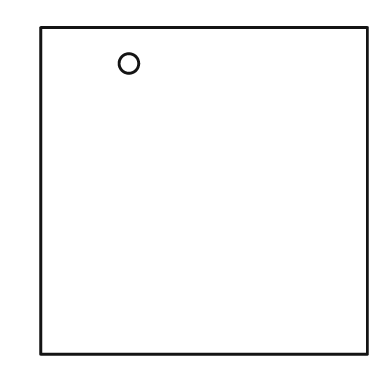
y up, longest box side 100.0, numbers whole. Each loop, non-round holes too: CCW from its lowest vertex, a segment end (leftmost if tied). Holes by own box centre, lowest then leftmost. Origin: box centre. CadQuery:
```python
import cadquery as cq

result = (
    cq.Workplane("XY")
    .moveTo(-50.0, -50.0)
    .lineTo(50.0, -50.0)
    .lineTo(50.0, 50.0)
    .lineTo(-50.0, 50.0)
    .close()
    .moveTo(-23.0, 39.0)
    .circle(3.0)
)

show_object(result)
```